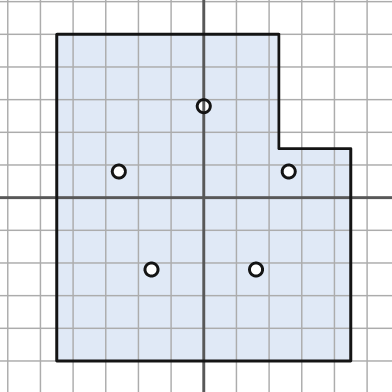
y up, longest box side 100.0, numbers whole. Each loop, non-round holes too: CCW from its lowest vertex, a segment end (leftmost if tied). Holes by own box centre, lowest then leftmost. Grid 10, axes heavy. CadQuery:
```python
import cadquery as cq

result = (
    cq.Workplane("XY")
    .moveTo(-45.0, -50.0)
    .lineTo(45.0, -50.0)
    .lineTo(45.0, 15.0)
    .lineTo(23.0, 15.0)
    .lineTo(23.0, 50.0)
    .lineTo(-45.0, 50.0)
    .close()
    .moveTo(-16.0, -22.0)
    .circle(2.0)
    .moveTo(16.0, -22.0)
    .circle(2.0)
    .moveTo(-26.0, 8.0)
    .circle(2.0)
    .moveTo(26.0, 8.0)
    .circle(2.0)
    .moveTo(0.0, 28.0)
    .circle(2.0)
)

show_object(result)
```